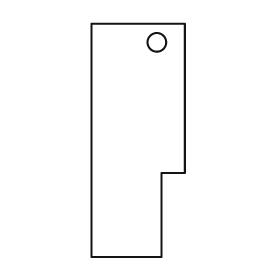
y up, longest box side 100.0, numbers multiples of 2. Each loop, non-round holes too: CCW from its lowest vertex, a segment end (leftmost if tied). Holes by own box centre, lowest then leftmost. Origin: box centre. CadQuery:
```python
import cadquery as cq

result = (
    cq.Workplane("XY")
    .moveTo(-20.0, -50.0)
    .lineTo(10.0, -50.0)
    .lineTo(10.0, -14.0)
    .lineTo(20.0, -14.0)
    .lineTo(20.0, 50.0)
    .lineTo(-20.0, 50.0)
    .close()
    .moveTo(8.0, 42.0)
    .circle(4.0)
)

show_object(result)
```